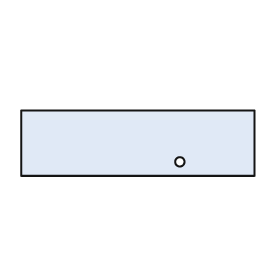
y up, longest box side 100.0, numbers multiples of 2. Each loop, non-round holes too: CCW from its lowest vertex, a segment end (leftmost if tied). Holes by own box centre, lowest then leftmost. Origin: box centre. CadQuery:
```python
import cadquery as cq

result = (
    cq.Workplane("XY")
    .moveTo(-50.0, -14.0)
    .lineTo(50.0, -14.0)
    .lineTo(50.0, 14.0)
    .lineTo(-50.0, 14.0)
    .close()
    .moveTo(18.0, -8.0)
    .circle(2.0)
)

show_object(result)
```